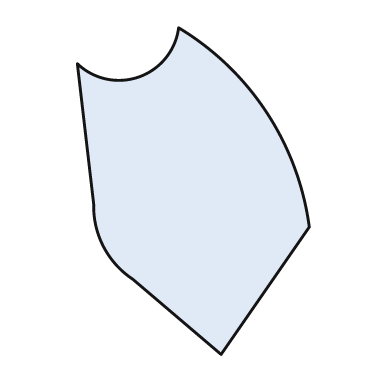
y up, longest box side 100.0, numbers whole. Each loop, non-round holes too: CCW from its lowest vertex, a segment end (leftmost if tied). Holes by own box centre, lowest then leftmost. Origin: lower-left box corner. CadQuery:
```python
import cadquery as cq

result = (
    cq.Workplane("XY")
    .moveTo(44.0, 0.0)
    .lineTo(71.0, 39.0)
    .threePointArc((58.0, 74.0), (31.0, 100.0))
    .threePointArc((19.0, 85.0), (0.0, 89.0))
    .lineTo(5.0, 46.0)
    .threePointArc((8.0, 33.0), (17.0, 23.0))
    .close()
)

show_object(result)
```